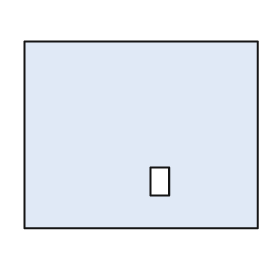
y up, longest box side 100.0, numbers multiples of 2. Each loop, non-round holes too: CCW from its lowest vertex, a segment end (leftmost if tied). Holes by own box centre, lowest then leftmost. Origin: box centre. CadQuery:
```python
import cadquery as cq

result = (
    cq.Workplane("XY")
    .moveTo(-50.0, -40.0)
    .lineTo(50.0, -40.0)
    .lineTo(50.0, 40.0)
    .lineTo(-50.0, 40.0)
    .close()
    .moveTo(4.0, -26.0)
    .lineTo(12.0, -26.0)
    .lineTo(12.0, -14.0)
    .lineTo(4.0, -14.0)
    .close()
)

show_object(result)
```